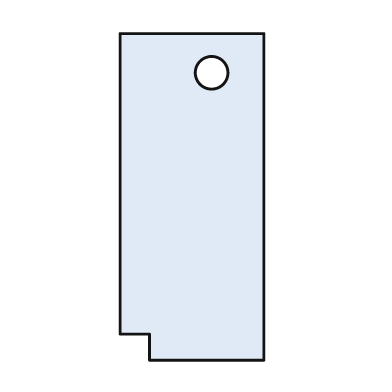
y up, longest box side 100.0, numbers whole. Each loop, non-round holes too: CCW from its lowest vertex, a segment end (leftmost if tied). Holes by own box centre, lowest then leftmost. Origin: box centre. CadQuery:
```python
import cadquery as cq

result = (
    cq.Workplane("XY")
    .moveTo(-13.0, -50.0)
    .lineTo(22.0, -50.0)
    .lineTo(22.0, 50.0)
    .lineTo(-22.0, 50.0)
    .lineTo(-22.0, -42.0)
    .lineTo(-13.0, -42.0)
    .close()
    .moveTo(6.0, 38.0)
    .circle(5.0)
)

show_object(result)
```